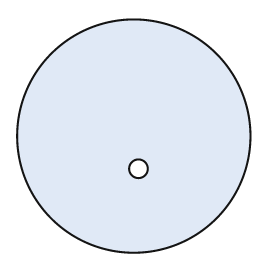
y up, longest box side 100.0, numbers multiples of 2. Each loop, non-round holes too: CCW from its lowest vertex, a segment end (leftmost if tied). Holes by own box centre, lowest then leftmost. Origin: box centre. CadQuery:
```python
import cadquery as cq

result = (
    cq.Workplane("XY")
    .moveTo(0.0, 0.0)
    .circle(50.0)
    .moveTo(2.0, -14.0)
    .circle(4.0)
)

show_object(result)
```